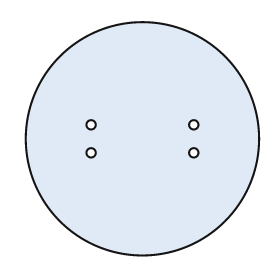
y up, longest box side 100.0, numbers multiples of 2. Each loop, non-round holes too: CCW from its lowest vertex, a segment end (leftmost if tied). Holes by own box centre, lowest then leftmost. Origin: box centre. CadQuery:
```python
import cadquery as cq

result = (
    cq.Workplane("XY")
    .moveTo(0.0, 0.0)
    .circle(50.0)
    .moveTo(-22.0, -6.0)
    .circle(2.0)
    .moveTo(22.0, -6.0)
    .circle(2.0)
    .moveTo(-22.0, 6.0)
    .circle(2.0)
    .moveTo(22.0, 6.0)
    .circle(2.0)
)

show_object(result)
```